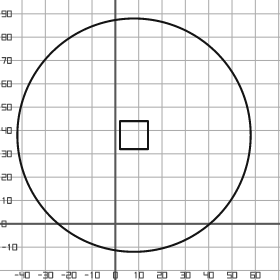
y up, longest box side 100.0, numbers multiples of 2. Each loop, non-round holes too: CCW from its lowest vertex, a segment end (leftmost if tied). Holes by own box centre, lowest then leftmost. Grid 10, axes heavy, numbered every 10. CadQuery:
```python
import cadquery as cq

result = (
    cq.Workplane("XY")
    .moveTo(8.0, 38.0)
    .circle(50.0)
    .moveTo(2.0, 32.0)
    .lineTo(14.0, 32.0)
    .lineTo(14.0, 44.0)
    .lineTo(2.0, 44.0)
    .close()
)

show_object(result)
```